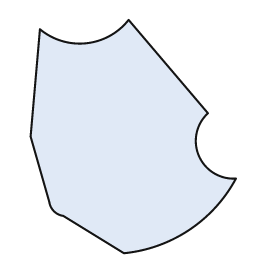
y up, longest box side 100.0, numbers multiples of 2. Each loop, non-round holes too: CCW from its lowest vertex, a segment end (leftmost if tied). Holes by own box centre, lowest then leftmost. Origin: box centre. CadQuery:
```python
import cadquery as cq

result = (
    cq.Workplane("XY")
    .moveTo(-4.0, -50.0)
    .threePointArc((24.0, -40.0), (44.0, -18.0))
    .threePointArc((28.0, -8.0), (32.0, 10.0))
    .lineTo(-2.0, 50.0)
    .threePointArc((-20.0, 40.0), (-40.0, 46.0))
    .lineTo(-44.0, 0.0)
    .lineTo(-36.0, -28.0)
    .threePointArc((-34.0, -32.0), (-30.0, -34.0))
    .close()
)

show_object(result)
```